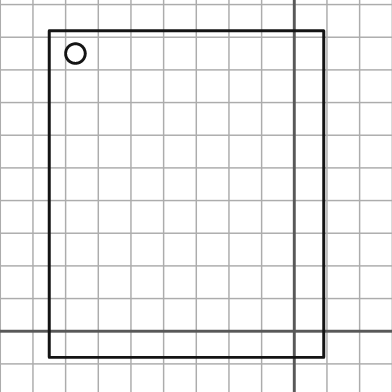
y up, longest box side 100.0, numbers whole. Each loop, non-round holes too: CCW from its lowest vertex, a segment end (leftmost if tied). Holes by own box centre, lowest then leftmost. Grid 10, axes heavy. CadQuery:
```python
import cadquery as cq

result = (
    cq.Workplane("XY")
    .moveTo(-75.0, -8.0)
    .lineTo(9.0, -8.0)
    .lineTo(9.0, 92.0)
    .lineTo(-75.0, 92.0)
    .close()
    .moveTo(-67.0, 85.0)
    .circle(3.0)
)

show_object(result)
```